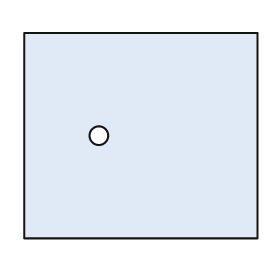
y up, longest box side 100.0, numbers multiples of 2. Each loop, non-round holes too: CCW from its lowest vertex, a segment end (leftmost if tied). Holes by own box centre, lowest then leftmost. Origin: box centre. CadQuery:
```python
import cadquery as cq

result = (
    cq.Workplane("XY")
    .moveTo(-50.0, -44.0)
    .lineTo(50.0, -44.0)
    .lineTo(50.0, 44.0)
    .lineTo(-50.0, 44.0)
    .close()
    .moveTo(-18.0, 0.0)
    .circle(4.0)
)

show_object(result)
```